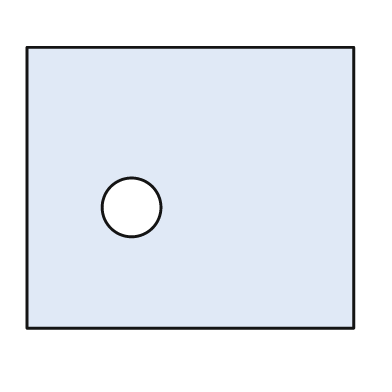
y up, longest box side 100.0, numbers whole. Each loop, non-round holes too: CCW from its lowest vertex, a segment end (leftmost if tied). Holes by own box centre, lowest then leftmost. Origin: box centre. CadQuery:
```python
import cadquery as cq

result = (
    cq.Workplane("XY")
    .moveTo(-50.0, -43.0)
    .lineTo(50.0, -43.0)
    .lineTo(50.0, 43.0)
    .lineTo(-50.0, 43.0)
    .close()
    .moveTo(-18.0, -6.0)
    .circle(9.0)
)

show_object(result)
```